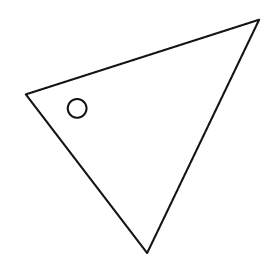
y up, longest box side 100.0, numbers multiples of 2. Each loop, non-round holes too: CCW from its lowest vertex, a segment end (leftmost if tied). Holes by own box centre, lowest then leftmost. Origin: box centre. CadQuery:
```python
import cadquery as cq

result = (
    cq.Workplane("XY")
    .moveTo(2.0, -50.0)
    .lineTo(50.0, 50.0)
    .lineTo(-50.0, 18.0)
    .close()
    .moveTo(-28.0, 12.0)
    .circle(4.0)
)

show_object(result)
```